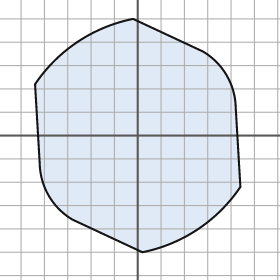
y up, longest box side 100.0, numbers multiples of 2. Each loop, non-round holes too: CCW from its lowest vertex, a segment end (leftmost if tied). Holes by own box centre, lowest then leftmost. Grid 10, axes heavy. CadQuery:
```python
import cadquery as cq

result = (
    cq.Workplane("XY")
    .moveTo(2.0, -50.0)
    .threePointArc((26.0, -40.0), (44.0, -22.0))
    .lineTo(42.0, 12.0)
    .threePointArc((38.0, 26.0), (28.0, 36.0))
    .lineTo(-2.0, 50.0)
    .threePointArc((-26.0, 40.0), (-44.0, 22.0))
    .lineTo(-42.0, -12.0)
    .threePointArc((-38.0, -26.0), (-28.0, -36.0))
    .close()
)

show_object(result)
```